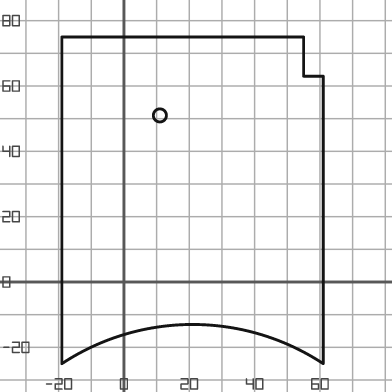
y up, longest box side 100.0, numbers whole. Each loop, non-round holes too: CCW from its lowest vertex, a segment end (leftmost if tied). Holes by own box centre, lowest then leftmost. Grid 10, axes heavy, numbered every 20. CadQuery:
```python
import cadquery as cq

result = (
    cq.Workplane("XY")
    .moveTo(-19.0, -25.0)
    .threePointArc((21.0, -13.0), (61.0, -25.0))
    .lineTo(61.0, 63.0)
    .lineTo(55.0, 63.0)
    .lineTo(55.0, 75.0)
    .lineTo(-19.0, 75.0)
    .close()
    .moveTo(11.0, 51.0)
    .circle(2.0)
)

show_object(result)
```